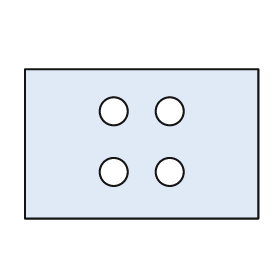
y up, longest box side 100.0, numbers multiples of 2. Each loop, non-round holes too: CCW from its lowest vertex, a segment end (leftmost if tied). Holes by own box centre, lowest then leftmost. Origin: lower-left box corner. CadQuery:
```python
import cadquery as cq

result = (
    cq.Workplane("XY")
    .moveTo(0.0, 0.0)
    .lineTo(100.0, 0.0)
    .lineTo(100.0, 64.0)
    .lineTo(0.0, 64.0)
    .close()
    .moveTo(38.0, 20.0)
    .circle(6.0)
    .moveTo(62.0, 20.0)
    .circle(6.0)
    .moveTo(38.0, 46.0)
    .circle(6.0)
    .moveTo(62.0, 46.0)
    .circle(6.0)
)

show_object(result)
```